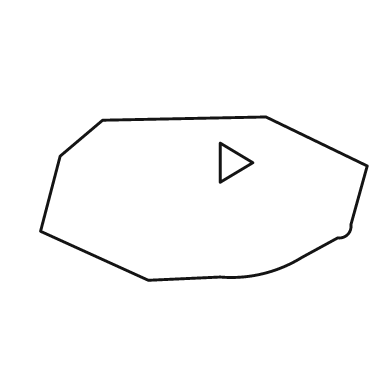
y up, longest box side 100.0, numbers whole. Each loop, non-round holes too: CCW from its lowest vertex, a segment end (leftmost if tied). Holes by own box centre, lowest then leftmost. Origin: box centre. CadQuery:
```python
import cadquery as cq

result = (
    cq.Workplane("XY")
    .moveTo(-17.0, -25.0)
    .lineTo(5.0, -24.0)
    .threePointArc((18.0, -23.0), (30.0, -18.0))
    .lineTo(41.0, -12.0)
    .threePointArc((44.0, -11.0), (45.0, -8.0))
    .lineTo(50.0, 10.0)
    .lineTo(19.0, 25.0)
    .lineTo(-31.0, 24.0)
    .lineTo(-44.0, 13.0)
    .lineTo(-50.0, -10.0)
    .close()
    .moveTo(5.0, 5.0)
    .lineTo(15.0, 11.0)
    .lineTo(5.0, 17.0)
    .close()
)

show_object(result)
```